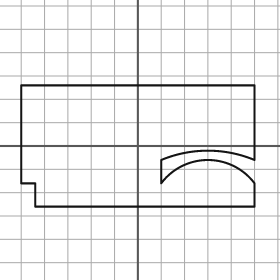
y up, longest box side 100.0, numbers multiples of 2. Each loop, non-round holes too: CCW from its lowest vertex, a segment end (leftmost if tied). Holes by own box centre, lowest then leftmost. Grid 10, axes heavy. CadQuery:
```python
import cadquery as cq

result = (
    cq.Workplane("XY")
    .moveTo(-44.0, -26.0)
    .lineTo(50.0, -26.0)
    .lineTo(50.0, -16.0)
    .threePointArc((30.0, -6.0), (10.0, -16.0))
    .lineTo(10.0, -6.0)
    .threePointArc((30.0, -2.0), (50.0, -6.0))
    .lineTo(50.0, 26.0)
    .lineTo(-50.0, 26.0)
    .lineTo(-50.0, -16.0)
    .lineTo(-44.0, -16.0)
    .close()
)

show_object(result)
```